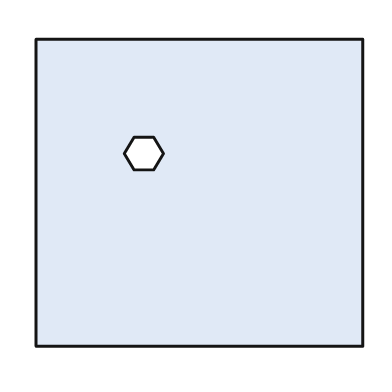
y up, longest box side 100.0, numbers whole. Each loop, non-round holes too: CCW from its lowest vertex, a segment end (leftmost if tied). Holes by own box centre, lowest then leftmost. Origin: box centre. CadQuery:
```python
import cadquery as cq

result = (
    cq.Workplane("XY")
    .moveTo(-50.0, -47.0)
    .lineTo(50.0, -47.0)
    .lineTo(50.0, 47.0)
    .lineTo(-50.0, 47.0)
    .close()
    .moveTo(-20.0, 7.0)
    .lineTo(-14.0, 7.0)
    .lineTo(-11.0, 12.0)
    .lineTo(-14.0, 17.0)
    .lineTo(-20.0, 17.0)
    .lineTo(-23.0, 12.0)
    .close()
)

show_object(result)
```